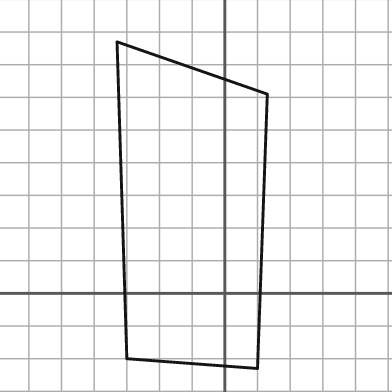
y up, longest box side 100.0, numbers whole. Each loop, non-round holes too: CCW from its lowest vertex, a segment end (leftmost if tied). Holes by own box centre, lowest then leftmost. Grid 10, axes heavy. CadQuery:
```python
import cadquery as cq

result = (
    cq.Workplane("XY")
    .moveTo(10.0, -23.0)
    .lineTo(13.0, 61.0)
    .lineTo(-33.0, 77.0)
    .lineTo(-30.0, -20.0)
    .close()
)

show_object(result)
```